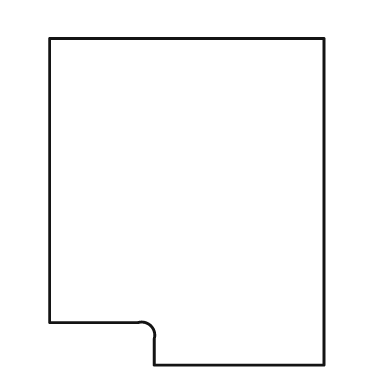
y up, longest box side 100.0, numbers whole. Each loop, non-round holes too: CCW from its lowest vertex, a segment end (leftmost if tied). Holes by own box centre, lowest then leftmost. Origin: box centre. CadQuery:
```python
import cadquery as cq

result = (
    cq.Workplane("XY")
    .moveTo(-10.0, -50.0)
    .lineTo(42.0, -50.0)
    .lineTo(42.0, 50.0)
    .lineTo(-42.0, 50.0)
    .lineTo(-42.0, -37.0)
    .lineTo(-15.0, -37.0)
    .threePointArc((-11.0, -38.0), (-10.0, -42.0))
    .close()
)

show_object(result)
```